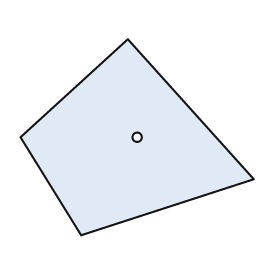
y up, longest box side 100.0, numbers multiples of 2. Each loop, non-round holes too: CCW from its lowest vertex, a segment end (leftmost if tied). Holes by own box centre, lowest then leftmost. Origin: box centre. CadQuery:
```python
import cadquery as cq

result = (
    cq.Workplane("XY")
    .moveTo(-24.0, -42.0)
    .lineTo(50.0, -18.0)
    .lineTo(-4.0, 42.0)
    .lineTo(-50.0, 0.0)
    .close()
    .moveTo(0.0, 0.0)
    .circle(2.0)
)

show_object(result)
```